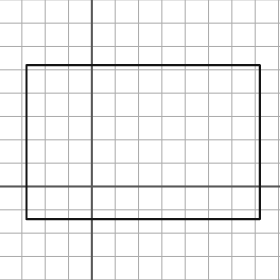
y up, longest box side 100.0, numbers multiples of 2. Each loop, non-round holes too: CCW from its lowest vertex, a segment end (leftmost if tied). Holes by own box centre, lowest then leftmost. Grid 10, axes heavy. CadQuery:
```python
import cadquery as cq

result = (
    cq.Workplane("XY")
    .moveTo(-28.0, -14.0)
    .lineTo(72.0, -14.0)
    .lineTo(72.0, 52.0)
    .lineTo(-28.0, 52.0)
    .close()
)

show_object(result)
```